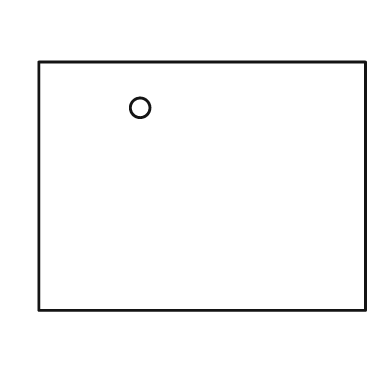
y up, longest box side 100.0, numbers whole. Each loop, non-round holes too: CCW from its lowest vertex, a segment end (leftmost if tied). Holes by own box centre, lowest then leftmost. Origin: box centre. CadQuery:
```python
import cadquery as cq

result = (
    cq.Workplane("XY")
    .moveTo(-50.0, -38.0)
    .lineTo(50.0, -38.0)
    .lineTo(50.0, 38.0)
    .lineTo(-50.0, 38.0)
    .close()
    .moveTo(-19.0, 24.0)
    .circle(3.0)
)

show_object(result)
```